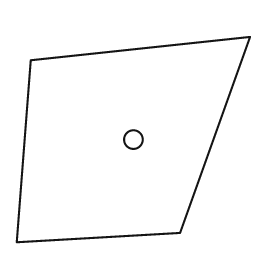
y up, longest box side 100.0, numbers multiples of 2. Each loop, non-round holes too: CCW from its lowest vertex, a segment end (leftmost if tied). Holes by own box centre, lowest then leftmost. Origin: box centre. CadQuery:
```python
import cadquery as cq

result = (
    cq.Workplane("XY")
    .moveTo(-50.0, -44.0)
    .lineTo(20.0, -40.0)
    .lineTo(50.0, 44.0)
    .lineTo(-44.0, 34.0)
    .close()
    .moveTo(0.0, 0.0)
    .circle(4.0)
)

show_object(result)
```